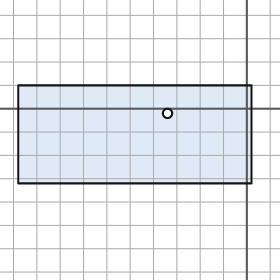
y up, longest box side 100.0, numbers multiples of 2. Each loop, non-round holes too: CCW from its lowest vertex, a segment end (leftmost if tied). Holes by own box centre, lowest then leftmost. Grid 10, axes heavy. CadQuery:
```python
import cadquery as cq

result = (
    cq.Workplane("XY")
    .moveTo(-98.0, -32.0)
    .lineTo(2.0, -32.0)
    .lineTo(2.0, 10.0)
    .lineTo(-98.0, 10.0)
    .close()
    .moveTo(-34.0, -2.0)
    .circle(2.0)
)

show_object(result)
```